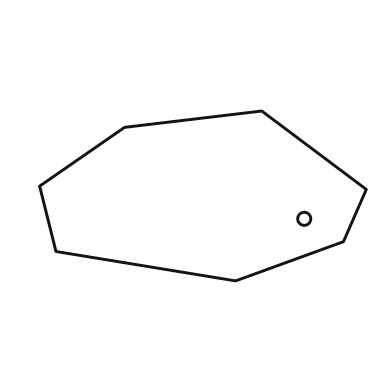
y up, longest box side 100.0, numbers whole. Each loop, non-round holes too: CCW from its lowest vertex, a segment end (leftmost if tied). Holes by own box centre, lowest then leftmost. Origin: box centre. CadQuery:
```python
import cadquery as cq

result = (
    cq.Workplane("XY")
    .moveTo(10.0, -26.0)
    .lineTo(43.0, -14.0)
    .lineTo(50.0, 2.0)
    .lineTo(18.0, 26.0)
    .lineTo(-24.0, 21.0)
    .lineTo(-50.0, 3.0)
    .lineTo(-45.0, -17.0)
    .close()
    .moveTo(31.0, -7.0)
    .circle(2.0)
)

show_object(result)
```